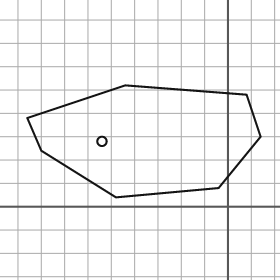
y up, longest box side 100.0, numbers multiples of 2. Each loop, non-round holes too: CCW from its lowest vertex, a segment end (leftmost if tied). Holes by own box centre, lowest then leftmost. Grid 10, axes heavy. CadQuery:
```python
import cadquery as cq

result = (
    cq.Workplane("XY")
    .moveTo(-48.0, 4.0)
    .lineTo(-4.0, 8.0)
    .lineTo(14.0, 30.0)
    .lineTo(8.0, 48.0)
    .lineTo(-44.0, 52.0)
    .lineTo(-86.0, 38.0)
    .lineTo(-80.0, 24.0)
    .close()
    .moveTo(-54.0, 28.0)
    .circle(2.0)
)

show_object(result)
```